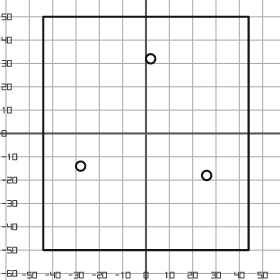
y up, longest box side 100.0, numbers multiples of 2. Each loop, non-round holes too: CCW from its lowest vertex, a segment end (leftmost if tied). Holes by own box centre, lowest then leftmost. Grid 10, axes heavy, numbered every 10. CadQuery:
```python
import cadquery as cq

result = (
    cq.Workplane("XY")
    .moveTo(-44.0, -50.0)
    .lineTo(44.0, -50.0)
    .lineTo(44.0, 50.0)
    .lineTo(-44.0, 50.0)
    .close()
    .moveTo(26.0, -18.0)
    .circle(2.0)
    .moveTo(-28.0, -14.0)
    .circle(2.0)
    .moveTo(2.0, 32.0)
    .circle(2.0)
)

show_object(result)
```